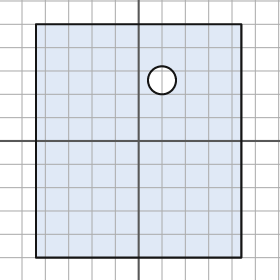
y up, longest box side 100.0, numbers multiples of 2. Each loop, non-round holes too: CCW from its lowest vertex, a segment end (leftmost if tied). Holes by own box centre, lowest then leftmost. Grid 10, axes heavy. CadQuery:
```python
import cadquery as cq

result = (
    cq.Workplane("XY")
    .moveTo(-44.0, -50.0)
    .lineTo(44.0, -50.0)
    .lineTo(44.0, 50.0)
    .lineTo(-44.0, 50.0)
    .close()
    .moveTo(10.0, 26.0)
    .circle(6.0)
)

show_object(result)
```